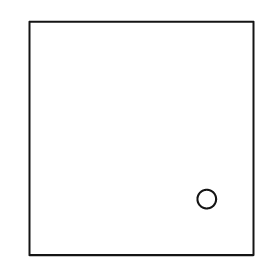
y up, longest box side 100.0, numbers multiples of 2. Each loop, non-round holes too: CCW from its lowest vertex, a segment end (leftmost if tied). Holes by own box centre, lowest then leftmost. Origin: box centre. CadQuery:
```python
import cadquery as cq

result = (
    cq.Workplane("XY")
    .moveTo(-48.0, -50.0)
    .lineTo(48.0, -50.0)
    .lineTo(48.0, 50.0)
    .lineTo(-48.0, 50.0)
    .close()
    .moveTo(28.0, -26.0)
    .circle(4.0)
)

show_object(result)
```